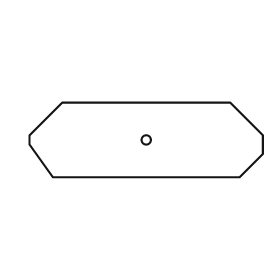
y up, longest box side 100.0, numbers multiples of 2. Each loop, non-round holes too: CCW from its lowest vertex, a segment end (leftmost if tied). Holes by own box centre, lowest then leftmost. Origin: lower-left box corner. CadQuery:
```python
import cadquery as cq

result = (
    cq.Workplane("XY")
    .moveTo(10.0, 0.0)
    .lineTo(90.0, 0.0)
    .lineTo(100.0, 10.0)
    .lineTo(100.0, 18.0)
    .lineTo(86.0, 32.0)
    .lineTo(14.0, 32.0)
    .lineTo(0.0, 18.0)
    .lineTo(0.0, 14.0)
    .close()
    .moveTo(50.0, 16.0)
    .circle(2.0)
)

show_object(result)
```